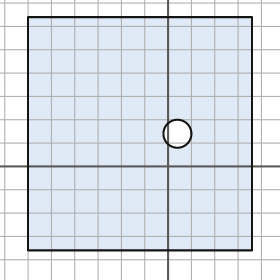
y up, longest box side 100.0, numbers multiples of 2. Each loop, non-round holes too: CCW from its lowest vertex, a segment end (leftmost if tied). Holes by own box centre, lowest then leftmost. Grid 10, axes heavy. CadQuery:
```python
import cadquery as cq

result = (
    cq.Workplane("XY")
    .moveTo(-60.0, -36.0)
    .lineTo(36.0, -36.0)
    .lineTo(36.0, 64.0)
    .lineTo(-60.0, 64.0)
    .close()
    .moveTo(4.0, 14.0)
    .circle(6.0)
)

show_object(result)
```